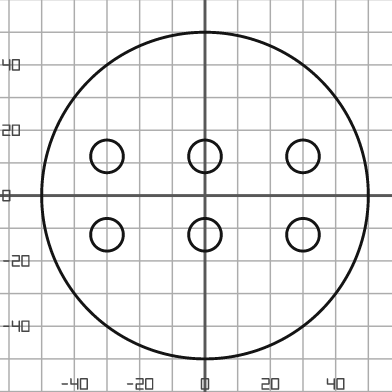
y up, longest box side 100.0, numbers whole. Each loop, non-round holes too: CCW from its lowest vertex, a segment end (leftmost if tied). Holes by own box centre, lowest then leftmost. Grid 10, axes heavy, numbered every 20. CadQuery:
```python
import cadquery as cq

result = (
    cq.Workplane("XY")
    .moveTo(0.0, 0.0)
    .circle(50.0)
    .moveTo(-30.0, -12.0)
    .circle(5.0)
    .moveTo(0.0, -12.0)
    .circle(5.0)
    .moveTo(30.0, -12.0)
    .circle(5.0)
    .moveTo(-30.0, 12.0)
    .circle(5.0)
    .moveTo(0.0, 12.0)
    .circle(5.0)
    .moveTo(30.0, 12.0)
    .circle(5.0)
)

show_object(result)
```